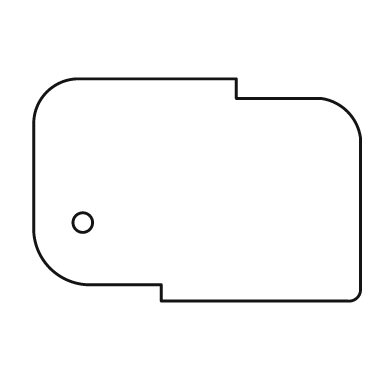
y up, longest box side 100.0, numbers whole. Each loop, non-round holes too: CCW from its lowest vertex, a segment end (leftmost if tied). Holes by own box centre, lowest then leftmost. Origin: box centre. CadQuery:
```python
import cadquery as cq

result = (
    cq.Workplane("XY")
    .moveTo(-11.0, -34.0)
    .lineTo(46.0, -34.0)
    .threePointArc((49.0, -33.0), (50.0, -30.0))
    .lineTo(50.0, 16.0)
    .threePointArc((46.0, 24.0), (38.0, 28.0))
    .lineTo(12.0, 28.0)
    .lineTo(12.0, 34.0)
    .lineTo(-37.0, 34.0)
    .threePointArc((-46.0, 30.0), (-50.0, 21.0))
    .lineTo(-50.0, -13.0)
    .threePointArc((-45.0, -24.0), (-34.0, -29.0))
    .lineTo(-11.0, -29.0)
    .close()
    .moveTo(-35.0, -10.0)
    .circle(3.0)
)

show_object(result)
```